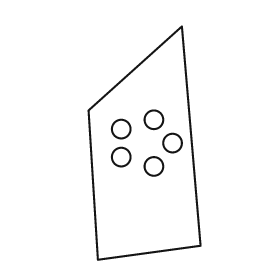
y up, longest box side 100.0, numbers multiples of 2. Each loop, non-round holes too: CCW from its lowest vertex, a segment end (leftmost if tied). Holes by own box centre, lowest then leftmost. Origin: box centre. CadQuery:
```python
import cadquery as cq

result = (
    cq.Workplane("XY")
    .moveTo(-20.0, -50.0)
    .lineTo(24.0, -44.0)
    .lineTo(16.0, 50.0)
    .lineTo(-24.0, 14.0)
    .close()
    .moveTo(4.0, -10.0)
    .circle(4.0)
    .moveTo(-10.0, -6.0)
    .circle(4.0)
    .moveTo(12.0, 0.0)
    .circle(4.0)
    .moveTo(-10.0, 6.0)
    .circle(4.0)
    .moveTo(4.0, 10.0)
    .circle(4.0)
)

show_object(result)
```